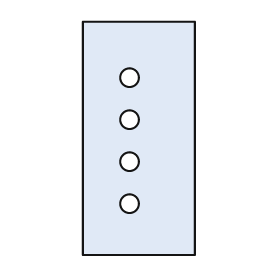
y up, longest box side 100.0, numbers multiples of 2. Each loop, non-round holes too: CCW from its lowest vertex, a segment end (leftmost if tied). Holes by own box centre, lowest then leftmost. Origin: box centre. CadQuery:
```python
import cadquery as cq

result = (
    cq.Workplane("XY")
    .moveTo(-24.0, -50.0)
    .lineTo(24.0, -50.0)
    .lineTo(24.0, 50.0)
    .lineTo(-24.0, 50.0)
    .close()
    .moveTo(-4.0, -28.0)
    .circle(4.0)
    .moveTo(-4.0, -10.0)
    .circle(4.0)
    .moveTo(-4.0, 8.0)
    .circle(4.0)
    .moveTo(-4.0, 26.0)
    .circle(4.0)
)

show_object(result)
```